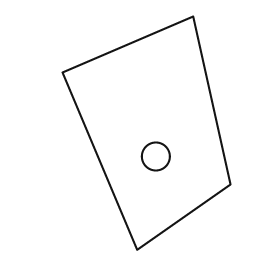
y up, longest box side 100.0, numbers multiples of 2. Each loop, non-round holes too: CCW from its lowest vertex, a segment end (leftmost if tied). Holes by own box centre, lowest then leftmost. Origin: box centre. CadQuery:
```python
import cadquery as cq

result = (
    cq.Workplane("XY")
    .moveTo(-4.0, -50.0)
    .lineTo(36.0, -22.0)
    .lineTo(20.0, 50.0)
    .lineTo(-36.0, 26.0)
    .close()
    .moveTo(4.0, -10.0)
    .circle(6.0)
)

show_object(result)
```